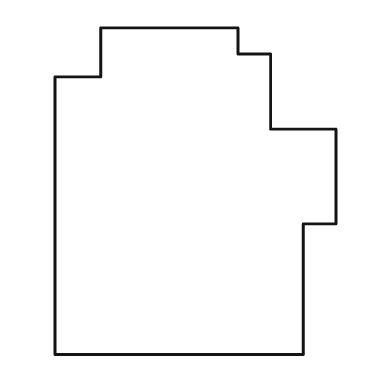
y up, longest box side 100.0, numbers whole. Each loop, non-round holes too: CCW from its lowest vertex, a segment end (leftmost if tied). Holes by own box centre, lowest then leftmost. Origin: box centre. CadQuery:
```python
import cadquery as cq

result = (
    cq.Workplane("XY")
    .moveTo(-43.0, -50.0)
    .lineTo(33.0, -50.0)
    .lineTo(33.0, -10.0)
    .lineTo(43.0, -10.0)
    .lineTo(43.0, 19.0)
    .lineTo(23.0, 19.0)
    .lineTo(23.0, 42.0)
    .lineTo(13.0, 42.0)
    .lineTo(13.0, 50.0)
    .lineTo(-29.0, 50.0)
    .lineTo(-29.0, 35.0)
    .lineTo(-43.0, 35.0)
    .close()
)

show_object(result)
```